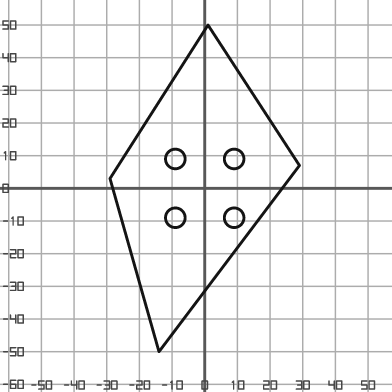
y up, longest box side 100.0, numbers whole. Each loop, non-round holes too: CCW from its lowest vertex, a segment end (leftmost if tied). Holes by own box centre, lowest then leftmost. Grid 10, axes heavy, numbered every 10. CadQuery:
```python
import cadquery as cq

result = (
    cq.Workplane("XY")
    .moveTo(-14.0, -50.0)
    .lineTo(29.0, 7.0)
    .lineTo(1.0, 50.0)
    .lineTo(-29.0, 3.0)
    .close()
    .moveTo(-9.0, -9.0)
    .circle(3.0)
    .moveTo(9.0, -9.0)
    .circle(3.0)
    .moveTo(-9.0, 9.0)
    .circle(3.0)
    .moveTo(9.0, 9.0)
    .circle(3.0)
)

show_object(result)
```